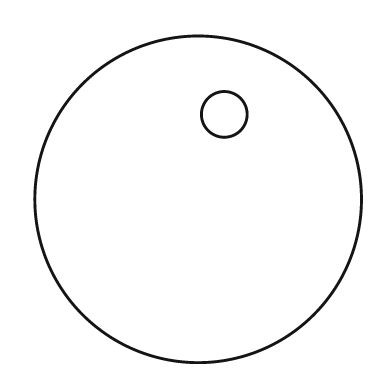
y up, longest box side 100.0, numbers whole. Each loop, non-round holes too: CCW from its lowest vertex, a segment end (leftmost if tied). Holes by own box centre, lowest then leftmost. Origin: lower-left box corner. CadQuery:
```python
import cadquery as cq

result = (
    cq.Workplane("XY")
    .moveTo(50.0, 50.0)
    .circle(50.0)
    .moveTo(58.0, 76.0)
    .circle(7.0)
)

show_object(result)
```